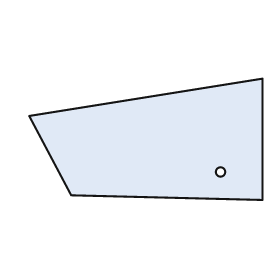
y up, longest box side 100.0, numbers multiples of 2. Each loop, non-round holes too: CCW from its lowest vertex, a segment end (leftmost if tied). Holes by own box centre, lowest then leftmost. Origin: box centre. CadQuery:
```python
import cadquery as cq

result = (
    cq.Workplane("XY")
    .moveTo(50.0, -26.0)
    .lineTo(50.0, 26.0)
    .lineTo(-50.0, 10.0)
    .lineTo(-32.0, -24.0)
    .close()
    .moveTo(32.0, -14.0)
    .circle(2.0)
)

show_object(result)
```